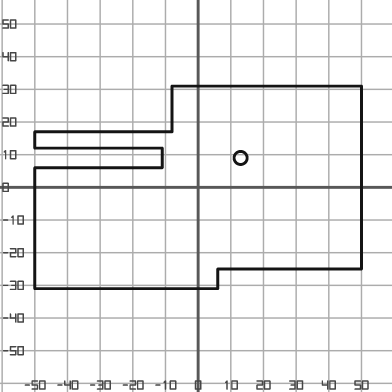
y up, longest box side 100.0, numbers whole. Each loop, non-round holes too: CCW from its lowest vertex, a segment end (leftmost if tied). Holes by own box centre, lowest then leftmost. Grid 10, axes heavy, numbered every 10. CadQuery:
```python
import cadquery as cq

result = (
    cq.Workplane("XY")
    .moveTo(-50.0, -31.0)
    .lineTo(6.0, -31.0)
    .lineTo(6.0, -25.0)
    .lineTo(50.0, -25.0)
    .lineTo(50.0, 31.0)
    .lineTo(-8.0, 31.0)
    .lineTo(-8.0, 17.0)
    .lineTo(-50.0, 17.0)
    .lineTo(-50.0, 12.0)
    .lineTo(-11.0, 12.0)
    .lineTo(-11.0, 6.0)
    .lineTo(-50.0, 6.0)
    .close()
    .moveTo(13.0, 9.0)
    .circle(2.0)
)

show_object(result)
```